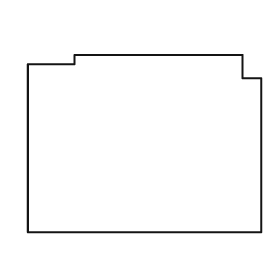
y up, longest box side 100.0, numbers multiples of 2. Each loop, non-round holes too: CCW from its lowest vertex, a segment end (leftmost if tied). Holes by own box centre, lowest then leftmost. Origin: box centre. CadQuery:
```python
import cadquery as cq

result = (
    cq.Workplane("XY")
    .moveTo(-50.0, -38.0)
    .lineTo(50.0, -38.0)
    .lineTo(50.0, 28.0)
    .lineTo(42.0, 28.0)
    .lineTo(42.0, 38.0)
    .lineTo(-30.0, 38.0)
    .lineTo(-30.0, 34.0)
    .lineTo(-50.0, 34.0)
    .close()
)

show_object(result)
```